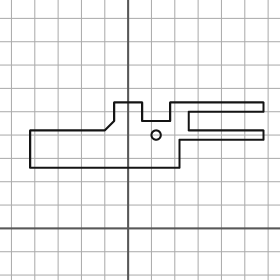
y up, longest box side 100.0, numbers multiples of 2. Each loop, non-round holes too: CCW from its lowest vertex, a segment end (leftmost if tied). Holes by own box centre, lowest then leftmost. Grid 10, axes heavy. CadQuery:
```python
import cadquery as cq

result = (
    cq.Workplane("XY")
    .moveTo(-42.0, 26.0)
    .lineTo(22.0, 26.0)
    .lineTo(22.0, 38.0)
    .lineTo(58.0, 38.0)
    .lineTo(58.0, 42.0)
    .lineTo(26.0, 42.0)
    .lineTo(26.0, 50.0)
    .lineTo(58.0, 50.0)
    .lineTo(58.0, 54.0)
    .lineTo(18.0, 54.0)
    .lineTo(18.0, 46.0)
    .lineTo(6.0, 46.0)
    .lineTo(6.0, 54.0)
    .lineTo(-6.0, 54.0)
    .lineTo(-6.0, 46.0)
    .lineTo(-10.0, 42.0)
    .lineTo(-42.0, 42.0)
    .close()
    .moveTo(12.0, 40.0)
    .circle(2.0)
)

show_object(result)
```